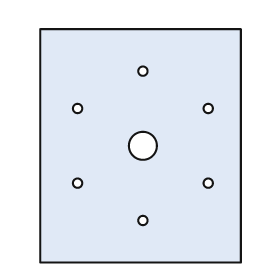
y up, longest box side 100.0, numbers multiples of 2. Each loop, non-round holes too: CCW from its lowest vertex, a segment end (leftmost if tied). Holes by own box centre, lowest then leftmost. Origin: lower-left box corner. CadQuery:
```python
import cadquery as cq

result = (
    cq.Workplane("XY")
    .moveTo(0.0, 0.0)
    .lineTo(86.0, 0.0)
    .lineTo(86.0, 100.0)
    .lineTo(0.0, 100.0)
    .close()
    .moveTo(44.0, 18.0)
    .circle(2.0)
    .moveTo(16.0, 34.0)
    .circle(2.0)
    .moveTo(72.0, 34.0)
    .circle(2.0)
    .moveTo(44.0, 50.0)
    .circle(6.0)
    .moveTo(16.0, 66.0)
    .circle(2.0)
    .moveTo(72.0, 66.0)
    .circle(2.0)
    .moveTo(44.0, 82.0)
    .circle(2.0)
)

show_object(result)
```